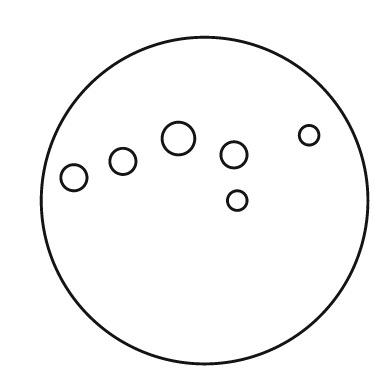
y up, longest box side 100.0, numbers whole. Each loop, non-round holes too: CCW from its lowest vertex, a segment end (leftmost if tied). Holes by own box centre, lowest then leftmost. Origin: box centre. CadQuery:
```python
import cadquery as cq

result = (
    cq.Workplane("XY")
    .moveTo(0.0, 0.0)
    .circle(50.0)
    .moveTo(10.0, 0.0)
    .circle(3.0)
    .moveTo(-40.0, 7.0)
    .circle(4.0)
    .moveTo(-25.0, 12.0)
    .circle(4.0)
    .moveTo(9.0, 14.0)
    .circle(4.0)
    .moveTo(-8.0, 19.0)
    .circle(5.0)
    .moveTo(32.0, 20.0)
    .circle(3.0)
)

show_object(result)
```